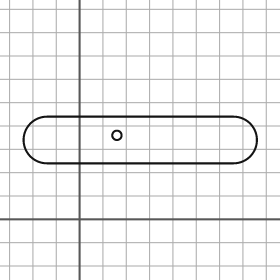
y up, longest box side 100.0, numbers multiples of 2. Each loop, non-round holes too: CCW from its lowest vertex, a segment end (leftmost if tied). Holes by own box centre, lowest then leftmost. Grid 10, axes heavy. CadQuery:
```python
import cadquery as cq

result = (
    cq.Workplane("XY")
    .moveTo(-14.0, 24.0)
    .lineTo(66.0, 24.0)
    .threePointArc((76.0, 34.0), (66.0, 44.0))
    .lineTo(-14.0, 44.0)
    .threePointArc((-24.0, 34.0), (-14.0, 24.0))
    .close()
    .moveTo(16.0, 36.0)
    .circle(2.0)
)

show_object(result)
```